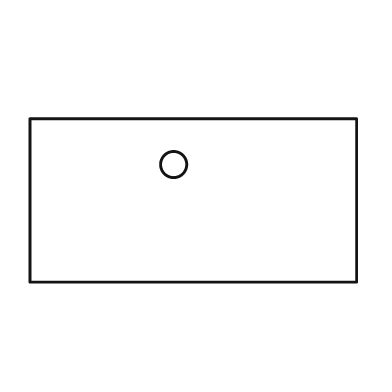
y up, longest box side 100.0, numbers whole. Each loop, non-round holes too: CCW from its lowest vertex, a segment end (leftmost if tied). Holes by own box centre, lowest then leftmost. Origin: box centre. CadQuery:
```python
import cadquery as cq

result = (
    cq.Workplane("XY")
    .moveTo(-50.0, -25.0)
    .lineTo(50.0, -25.0)
    .lineTo(50.0, 25.0)
    .lineTo(-50.0, 25.0)
    .close()
    .moveTo(-6.0, 11.0)
    .circle(4.0)
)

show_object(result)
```